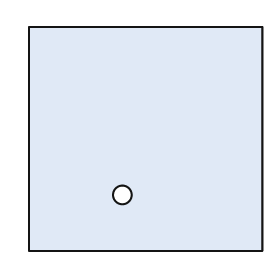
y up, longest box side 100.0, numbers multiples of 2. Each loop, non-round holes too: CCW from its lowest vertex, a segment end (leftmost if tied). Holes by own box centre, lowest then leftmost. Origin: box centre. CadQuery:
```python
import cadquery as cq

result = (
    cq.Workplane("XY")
    .moveTo(-50.0, -48.0)
    .lineTo(50.0, -48.0)
    .lineTo(50.0, 48.0)
    .lineTo(-50.0, 48.0)
    .close()
    .moveTo(-10.0, -24.0)
    .circle(4.0)
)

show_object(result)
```